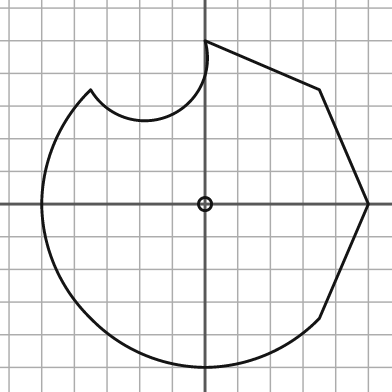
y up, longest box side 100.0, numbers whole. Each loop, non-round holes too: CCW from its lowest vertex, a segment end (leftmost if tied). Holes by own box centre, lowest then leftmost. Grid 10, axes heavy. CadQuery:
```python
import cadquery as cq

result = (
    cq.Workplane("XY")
    .moveTo(0.0, -50.0)
    .threePointArc((19.0, -46.0), (35.0, -35.0))
    .lineTo(50.0, 0.0)
    .lineTo(35.0, 35.0)
    .lineTo(0.0, 50.0)
    .threePointArc((-11.0, 27.0), (-35.0, 35.0))
    .threePointArc((-46.0, 19.0), (-50.0, 0.0))
    .threePointArc((-46.0, -19.0), (-35.0, -35.0))
    .threePointArc((-19.0, -46.0), (0.0, -50.0))
    .close()
    .moveTo(0.0, 0.0)
    .circle(2.0)
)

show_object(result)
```